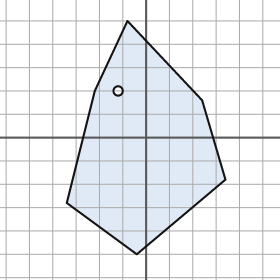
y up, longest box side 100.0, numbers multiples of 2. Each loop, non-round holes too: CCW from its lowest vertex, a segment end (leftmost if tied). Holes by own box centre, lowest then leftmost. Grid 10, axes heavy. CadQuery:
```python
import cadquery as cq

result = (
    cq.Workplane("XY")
    .moveTo(-4.0, -50.0)
    .lineTo(34.0, -18.0)
    .lineTo(24.0, 16.0)
    .lineTo(-8.0, 50.0)
    .lineTo(-22.0, 20.0)
    .lineTo(-34.0, -28.0)
    .close()
    .moveTo(-12.0, 20.0)
    .circle(2.0)
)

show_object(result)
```